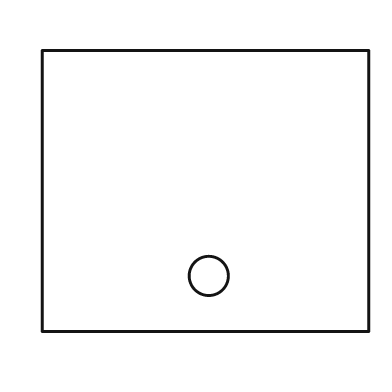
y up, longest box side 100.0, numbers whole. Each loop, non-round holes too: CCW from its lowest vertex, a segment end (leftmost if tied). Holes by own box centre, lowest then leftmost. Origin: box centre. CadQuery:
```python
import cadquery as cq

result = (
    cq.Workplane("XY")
    .moveTo(-50.0, -43.0)
    .lineTo(50.0, -43.0)
    .lineTo(50.0, 43.0)
    .lineTo(-50.0, 43.0)
    .close()
    .moveTo(1.0, -26.0)
    .circle(6.0)
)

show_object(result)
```